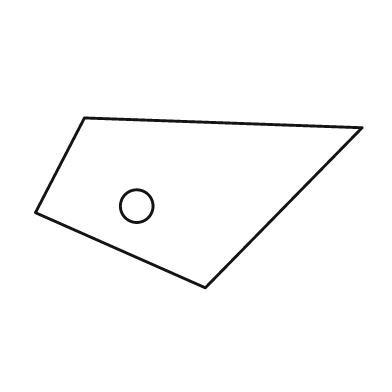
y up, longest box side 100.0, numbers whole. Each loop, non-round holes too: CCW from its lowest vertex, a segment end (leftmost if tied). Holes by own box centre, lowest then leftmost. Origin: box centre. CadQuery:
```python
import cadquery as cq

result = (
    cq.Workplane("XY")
    .moveTo(2.0, -26.0)
    .lineTo(50.0, 23.0)
    .lineTo(-35.0, 26.0)
    .lineTo(-50.0, -3.0)
    .close()
    .moveTo(-19.0, -1.0)
    .circle(5.0)
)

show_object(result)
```